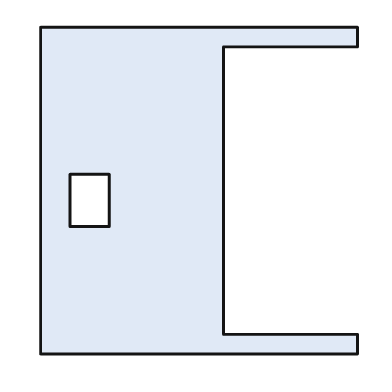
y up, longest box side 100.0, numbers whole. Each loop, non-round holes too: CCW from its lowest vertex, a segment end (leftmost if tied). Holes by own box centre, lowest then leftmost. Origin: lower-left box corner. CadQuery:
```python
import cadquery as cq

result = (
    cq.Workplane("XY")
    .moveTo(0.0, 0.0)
    .lineTo(97.0, 0.0)
    .lineTo(97.0, 6.0)
    .lineTo(56.0, 6.0)
    .lineTo(56.0, 94.0)
    .lineTo(97.0, 94.0)
    .lineTo(97.0, 100.0)
    .lineTo(0.0, 100.0)
    .close()
    .moveTo(9.0, 39.0)
    .lineTo(21.0, 39.0)
    .lineTo(21.0, 55.0)
    .lineTo(9.0, 55.0)
    .close()
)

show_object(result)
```